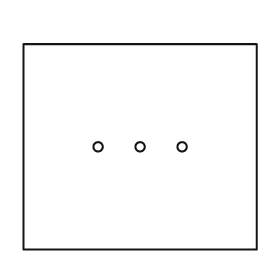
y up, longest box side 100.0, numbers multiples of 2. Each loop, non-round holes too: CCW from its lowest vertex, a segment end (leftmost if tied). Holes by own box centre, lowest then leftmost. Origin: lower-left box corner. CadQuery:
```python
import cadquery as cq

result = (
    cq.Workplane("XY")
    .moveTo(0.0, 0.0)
    .lineTo(100.0, 0.0)
    .lineTo(100.0, 88.0)
    .lineTo(0.0, 88.0)
    .close()
    .moveTo(32.0, 44.0)
    .circle(2.0)
    .moveTo(50.0, 44.0)
    .circle(2.0)
    .moveTo(68.0, 44.0)
    .circle(2.0)
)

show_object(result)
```